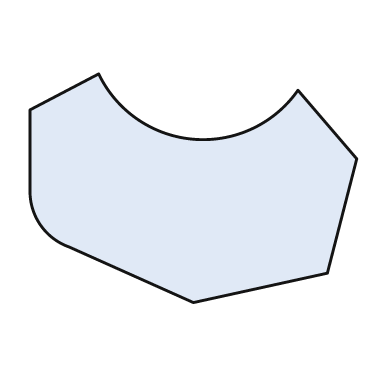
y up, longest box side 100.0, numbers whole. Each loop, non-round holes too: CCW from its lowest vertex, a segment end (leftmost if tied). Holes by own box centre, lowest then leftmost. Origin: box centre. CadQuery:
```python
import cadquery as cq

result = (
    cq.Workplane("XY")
    .moveTo(0.0, -35.0)
    .lineTo(41.0, -26.0)
    .lineTo(50.0, 9.0)
    .lineTo(32.0, 30.0)
    .threePointArc((0.0, 15.0), (-29.0, 35.0))
    .lineTo(-50.0, 24.0)
    .lineTo(-50.0, 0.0)
    .threePointArc((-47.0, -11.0), (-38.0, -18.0))
    .close()
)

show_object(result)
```